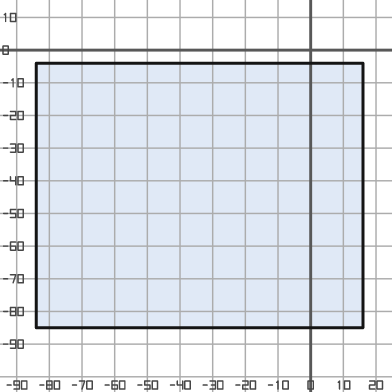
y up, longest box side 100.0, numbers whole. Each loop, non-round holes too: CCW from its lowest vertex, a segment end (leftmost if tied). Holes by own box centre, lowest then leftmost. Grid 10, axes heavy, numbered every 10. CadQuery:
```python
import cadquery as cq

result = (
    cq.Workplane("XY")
    .moveTo(-84.0, -85.0)
    .lineTo(16.0, -85.0)
    .lineTo(16.0, -4.0)
    .lineTo(-84.0, -4.0)
    .close()
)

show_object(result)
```